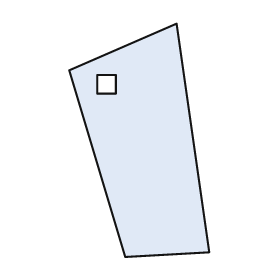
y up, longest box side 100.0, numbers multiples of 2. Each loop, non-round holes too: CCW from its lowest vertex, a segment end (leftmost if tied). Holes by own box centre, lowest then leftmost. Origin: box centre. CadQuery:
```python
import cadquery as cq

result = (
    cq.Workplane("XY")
    .moveTo(-6.0, -50.0)
    .lineTo(30.0, -48.0)
    .lineTo(16.0, 50.0)
    .lineTo(-30.0, 30.0)
    .close()
    .moveTo(-18.0, 20.0)
    .lineTo(-10.0, 20.0)
    .lineTo(-10.0, 28.0)
    .lineTo(-18.0, 28.0)
    .close()
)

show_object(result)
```